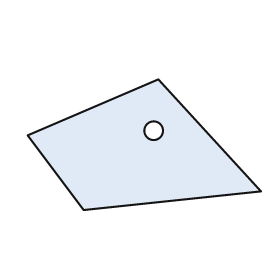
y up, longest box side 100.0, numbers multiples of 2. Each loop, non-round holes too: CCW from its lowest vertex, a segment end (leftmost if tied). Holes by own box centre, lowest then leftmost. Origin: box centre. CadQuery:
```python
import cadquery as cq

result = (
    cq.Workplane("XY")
    .moveTo(-26.0, -28.0)
    .lineTo(50.0, -20.0)
    .lineTo(6.0, 28.0)
    .lineTo(-50.0, 4.0)
    .close()
    .moveTo(4.0, 6.0)
    .circle(4.0)
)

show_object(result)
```